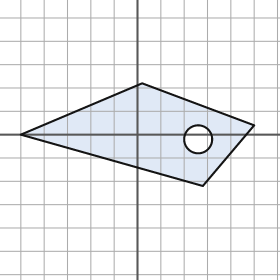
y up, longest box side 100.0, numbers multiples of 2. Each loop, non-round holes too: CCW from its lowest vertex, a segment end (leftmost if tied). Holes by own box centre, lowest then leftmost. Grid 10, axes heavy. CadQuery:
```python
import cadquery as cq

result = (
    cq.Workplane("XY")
    .moveTo(28.0, -22.0)
    .lineTo(50.0, 4.0)
    .lineTo(2.0, 22.0)
    .lineTo(-50.0, 0.0)
    .close()
    .moveTo(26.0, -2.0)
    .circle(6.0)
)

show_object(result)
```